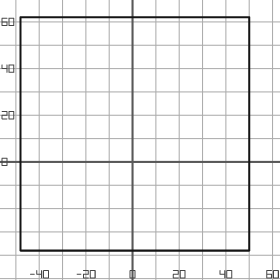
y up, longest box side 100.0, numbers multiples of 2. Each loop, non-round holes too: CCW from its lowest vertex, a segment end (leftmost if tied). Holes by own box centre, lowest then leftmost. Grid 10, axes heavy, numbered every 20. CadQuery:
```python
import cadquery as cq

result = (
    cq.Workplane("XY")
    .moveTo(-48.0, -38.0)
    .lineTo(50.0, -38.0)
    .lineTo(50.0, 62.0)
    .lineTo(-48.0, 62.0)
    .close()
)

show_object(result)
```